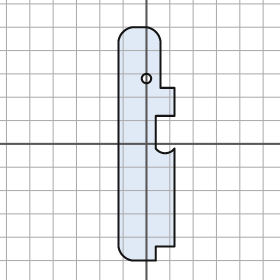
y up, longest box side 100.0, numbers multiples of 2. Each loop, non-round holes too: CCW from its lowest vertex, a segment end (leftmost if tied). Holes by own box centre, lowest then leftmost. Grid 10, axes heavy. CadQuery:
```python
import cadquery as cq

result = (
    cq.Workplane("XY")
    .moveTo(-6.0, -50.0)
    .lineTo(4.0, -50.0)
    .lineTo(4.0, -44.0)
    .lineTo(12.0, -44.0)
    .lineTo(12.0, -2.0)
    .threePointArc((8.0, -4.0), (4.0, -2.0))
    .lineTo(4.0, 12.0)
    .lineTo(12.0, 12.0)
    .lineTo(12.0, 24.0)
    .lineTo(6.0, 24.0)
    .lineTo(6.0, 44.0)
    .threePointArc((4.0, 48.0), (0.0, 50.0))
    .lineTo(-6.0, 50.0)
    .threePointArc((-10.0, 48.0), (-12.0, 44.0))
    .lineTo(-12.0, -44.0)
    .threePointArc((-10.0, -48.0), (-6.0, -50.0))
    .close()
    .moveTo(0.0, 28.0)
    .circle(2.0)
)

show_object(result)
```